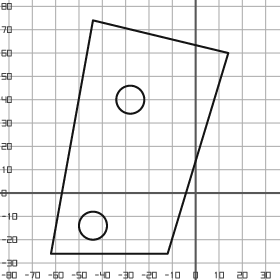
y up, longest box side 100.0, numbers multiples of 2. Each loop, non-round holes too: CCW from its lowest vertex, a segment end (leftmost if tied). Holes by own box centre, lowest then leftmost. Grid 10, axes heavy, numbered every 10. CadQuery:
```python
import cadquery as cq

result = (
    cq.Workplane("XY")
    .moveTo(-62.0, -26.0)
    .lineTo(-12.0, -26.0)
    .lineTo(14.0, 60.0)
    .lineTo(-44.0, 74.0)
    .close()
    .moveTo(-44.0, -14.0)
    .circle(6.0)
    .moveTo(-28.0, 40.0)
    .circle(6.0)
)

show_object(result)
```